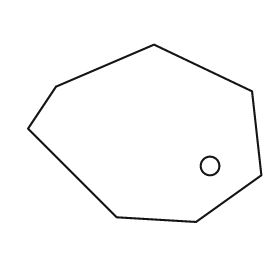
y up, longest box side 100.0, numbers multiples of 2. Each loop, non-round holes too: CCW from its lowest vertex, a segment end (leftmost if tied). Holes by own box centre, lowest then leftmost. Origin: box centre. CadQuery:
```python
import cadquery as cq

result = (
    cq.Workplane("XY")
    .moveTo(22.0, -38.0)
    .lineTo(50.0, -18.0)
    .lineTo(46.0, 18.0)
    .lineTo(4.0, 38.0)
    .lineTo(-38.0, 20.0)
    .lineTo(-50.0, 2.0)
    .lineTo(-12.0, -36.0)
    .close()
    .moveTo(28.0, -14.0)
    .circle(4.0)
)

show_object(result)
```